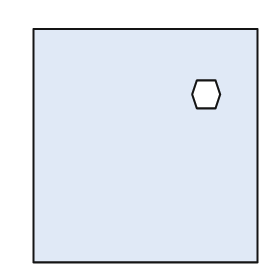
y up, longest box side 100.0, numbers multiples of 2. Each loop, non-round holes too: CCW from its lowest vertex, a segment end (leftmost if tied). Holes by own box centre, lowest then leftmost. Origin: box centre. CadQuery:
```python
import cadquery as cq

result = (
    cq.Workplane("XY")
    .moveTo(-48.0, -50.0)
    .lineTo(48.0, -50.0)
    .lineTo(48.0, 50.0)
    .lineTo(-48.0, 50.0)
    .close()
    .moveTo(22.0, 16.0)
    .lineTo(30.0, 16.0)
    .lineTo(32.0, 22.0)
    .lineTo(30.0, 28.0)
    .lineTo(22.0, 28.0)
    .lineTo(20.0, 22.0)
    .close()
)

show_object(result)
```